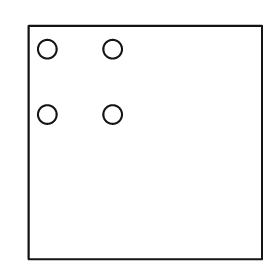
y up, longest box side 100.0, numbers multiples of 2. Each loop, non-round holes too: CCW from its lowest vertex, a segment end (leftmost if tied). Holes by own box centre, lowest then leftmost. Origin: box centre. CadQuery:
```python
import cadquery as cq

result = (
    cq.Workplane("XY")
    .moveTo(-50.0, -50.0)
    .lineTo(50.0, -50.0)
    .lineTo(50.0, 50.0)
    .lineTo(-50.0, 50.0)
    .close()
    .moveTo(-42.0, 12.0)
    .circle(4.0)
    .moveTo(-14.0, 12.0)
    .circle(4.0)
    .moveTo(-42.0, 40.0)
    .circle(4.0)
    .moveTo(-14.0, 40.0)
    .circle(4.0)
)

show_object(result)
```